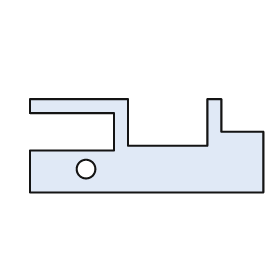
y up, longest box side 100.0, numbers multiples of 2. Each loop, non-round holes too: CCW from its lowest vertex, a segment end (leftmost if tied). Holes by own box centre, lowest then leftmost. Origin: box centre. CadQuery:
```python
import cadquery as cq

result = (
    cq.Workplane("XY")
    .moveTo(-50.0, -20.0)
    .lineTo(50.0, -20.0)
    .lineTo(50.0, 6.0)
    .lineTo(32.0, 6.0)
    .lineTo(32.0, 20.0)
    .lineTo(26.0, 20.0)
    .lineTo(26.0, 0.0)
    .lineTo(-8.0, 0.0)
    .lineTo(-8.0, 20.0)
    .lineTo(-50.0, 20.0)
    .lineTo(-50.0, 14.0)
    .lineTo(-14.0, 14.0)
    .lineTo(-14.0, -2.0)
    .lineTo(-50.0, -2.0)
    .close()
    .moveTo(-26.0, -10.0)
    .circle(4.0)
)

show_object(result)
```